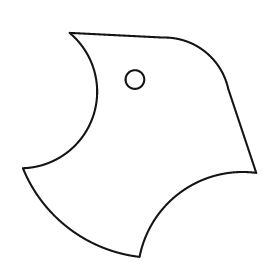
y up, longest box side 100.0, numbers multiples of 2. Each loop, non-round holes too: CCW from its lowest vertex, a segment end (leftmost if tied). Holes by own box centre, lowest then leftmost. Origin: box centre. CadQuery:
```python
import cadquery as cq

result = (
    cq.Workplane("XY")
    .moveTo(0.0, -48.0)
    .threePointArc((18.0, -20.0), (50.0, -12.0))
    .lineTo(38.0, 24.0)
    .threePointArc((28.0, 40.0), (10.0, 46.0))
    .lineTo(-30.0, 48.0)
    .threePointArc((-20.0, 12.0), (-50.0, -10.0))
    .threePointArc((-30.0, -36.0), (0.0, -48.0))
    .close()
    .moveTo(-2.0, 28.0)
    .circle(4.0)
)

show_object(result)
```